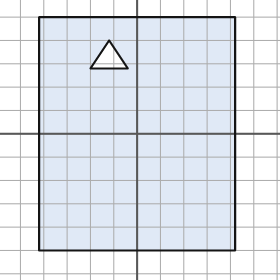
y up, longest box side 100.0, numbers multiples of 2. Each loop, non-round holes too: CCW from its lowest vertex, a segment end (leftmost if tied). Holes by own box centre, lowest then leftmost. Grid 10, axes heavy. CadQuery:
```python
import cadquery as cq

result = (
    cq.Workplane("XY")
    .moveTo(-42.0, -50.0)
    .lineTo(42.0, -50.0)
    .lineTo(42.0, 50.0)
    .lineTo(-42.0, 50.0)
    .close()
    .moveTo(-20.0, 28.0)
    .lineTo(-4.0, 28.0)
    .lineTo(-12.0, 40.0)
    .close()
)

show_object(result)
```